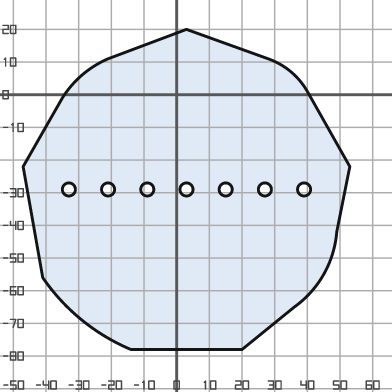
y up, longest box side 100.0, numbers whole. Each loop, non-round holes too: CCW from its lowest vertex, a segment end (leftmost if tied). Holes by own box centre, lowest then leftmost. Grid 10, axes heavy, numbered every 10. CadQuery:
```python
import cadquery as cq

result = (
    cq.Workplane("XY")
    .moveTo(-14.0, -78.0)
    .lineTo(20.0, -78.0)
    .lineTo(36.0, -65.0)
    .threePointArc((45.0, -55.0), (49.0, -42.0))
    .lineTo(53.0, -22.0)
    .lineTo(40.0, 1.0)
    .threePointArc((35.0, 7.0), (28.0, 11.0))
    .lineTo(3.0, 20.0)
    .lineTo(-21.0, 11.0)
    .threePointArc((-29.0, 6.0), (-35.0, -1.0))
    .lineTo(-47.0, -22.0)
    .lineTo(-41.0, -56.0)
    .threePointArc((-29.0, -69.0), (-14.0, -78.0))
    .close()
    .moveTo(-33.0, -29.0)
    .circle(2.0)
    .moveTo(-21.0, -29.0)
    .circle(2.0)
    .moveTo(-9.0, -29.0)
    .circle(2.0)
    .moveTo(3.0, -29.0)
    .circle(2.0)
    .moveTo(15.0, -29.0)
    .circle(2.0)
    .moveTo(27.0, -29.0)
    .circle(2.0)
    .moveTo(39.0, -29.0)
    .circle(2.0)
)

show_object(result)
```